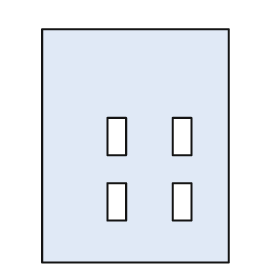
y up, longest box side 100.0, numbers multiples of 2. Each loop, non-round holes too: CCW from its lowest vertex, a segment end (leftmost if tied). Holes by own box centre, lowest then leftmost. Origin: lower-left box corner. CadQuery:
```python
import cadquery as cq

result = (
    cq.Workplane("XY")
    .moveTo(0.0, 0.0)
    .lineTo(80.0, 0.0)
    .lineTo(80.0, 100.0)
    .lineTo(0.0, 100.0)
    .close()
    .moveTo(28.0, 18.0)
    .lineTo(36.0, 18.0)
    .lineTo(36.0, 34.0)
    .lineTo(28.0, 34.0)
    .close()
    .moveTo(56.0, 18.0)
    .lineTo(64.0, 18.0)
    .lineTo(64.0, 34.0)
    .lineTo(56.0, 34.0)
    .close()
    .moveTo(28.0, 46.0)
    .lineTo(36.0, 46.0)
    .lineTo(36.0, 62.0)
    .lineTo(28.0, 62.0)
    .close()
    .moveTo(56.0, 46.0)
    .lineTo(64.0, 46.0)
    .lineTo(64.0, 62.0)
    .lineTo(56.0, 62.0)
    .close()
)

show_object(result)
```